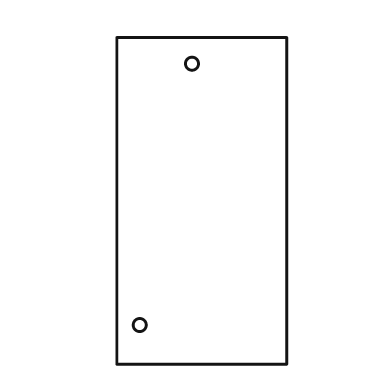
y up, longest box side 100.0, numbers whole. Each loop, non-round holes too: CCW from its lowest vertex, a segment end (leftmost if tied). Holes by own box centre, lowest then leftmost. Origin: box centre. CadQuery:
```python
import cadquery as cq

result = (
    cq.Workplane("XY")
    .moveTo(-26.0, -50.0)
    .lineTo(26.0, -50.0)
    .lineTo(26.0, 50.0)
    .lineTo(-26.0, 50.0)
    .close()
    .moveTo(-19.0, -38.0)
    .circle(2.0)
    .moveTo(-3.0, 42.0)
    .circle(2.0)
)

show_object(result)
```